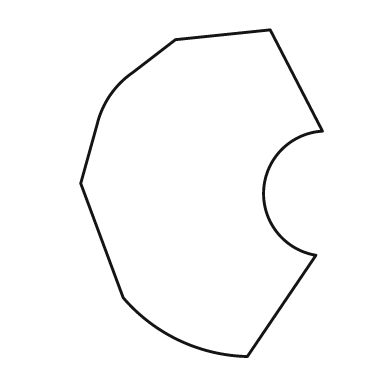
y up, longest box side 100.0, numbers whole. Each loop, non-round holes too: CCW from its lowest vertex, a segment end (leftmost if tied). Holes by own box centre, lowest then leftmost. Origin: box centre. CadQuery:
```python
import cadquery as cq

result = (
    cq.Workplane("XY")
    .moveTo(14.0, -50.0)
    .lineTo(35.0, -19.0)
    .threePointArc((19.0, 1.0), (37.0, 19.0))
    .lineTo(21.0, 50.0)
    .lineTo(-8.0, 47.0)
    .lineTo(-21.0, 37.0)
    .threePointArc((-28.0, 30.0), (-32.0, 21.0))
    .lineTo(-37.0, 3.0)
    .lineTo(-24.0, -32.0)
    .threePointArc((-7.0, -45.0), (14.0, -50.0))
    .close()
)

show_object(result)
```